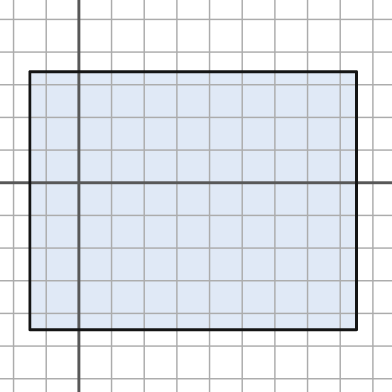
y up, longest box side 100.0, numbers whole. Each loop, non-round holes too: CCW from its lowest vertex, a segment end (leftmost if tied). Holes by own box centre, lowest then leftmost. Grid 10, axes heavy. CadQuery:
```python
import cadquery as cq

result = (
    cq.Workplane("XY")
    .moveTo(-15.0, -45.0)
    .lineTo(85.0, -45.0)
    .lineTo(85.0, 34.0)
    .lineTo(-15.0, 34.0)
    .close()
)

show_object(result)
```